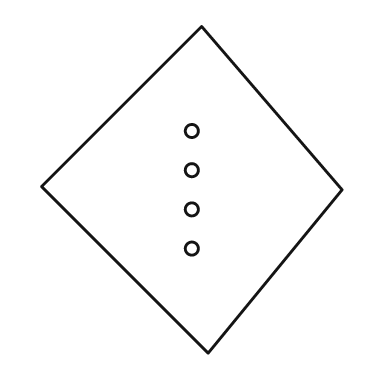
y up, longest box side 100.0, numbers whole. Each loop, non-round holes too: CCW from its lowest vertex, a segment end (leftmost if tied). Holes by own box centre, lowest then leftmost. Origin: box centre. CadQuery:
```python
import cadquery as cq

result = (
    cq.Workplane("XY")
    .moveTo(5.0, -50.0)
    .lineTo(46.0, 0.0)
    .lineTo(3.0, 50.0)
    .lineTo(-46.0, 1.0)
    .close()
    .moveTo(0.0, -18.0)
    .circle(2.0)
    .moveTo(0.0, -6.0)
    .circle(2.0)
    .moveTo(0.0, 6.0)
    .circle(2.0)
    .moveTo(0.0, 18.0)
    .circle(2.0)
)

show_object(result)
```